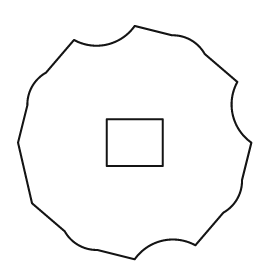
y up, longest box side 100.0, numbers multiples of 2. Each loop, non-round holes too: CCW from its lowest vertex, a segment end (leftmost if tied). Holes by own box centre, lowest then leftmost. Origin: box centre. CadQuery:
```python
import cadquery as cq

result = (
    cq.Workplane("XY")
    .moveTo(0.0, -50.0)
    .threePointArc((12.0, -42.0), (26.0, -44.0))
    .lineTo(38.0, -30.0)
    .threePointArc((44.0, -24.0), (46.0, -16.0))
    .lineTo(50.0, 0.0)
    .threePointArc((42.0, 12.0), (44.0, 26.0))
    .lineTo(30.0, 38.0)
    .threePointArc((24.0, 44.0), (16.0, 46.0))
    .lineTo(0.0, 50.0)
    .threePointArc((-12.0, 42.0), (-26.0, 44.0))
    .lineTo(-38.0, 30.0)
    .threePointArc((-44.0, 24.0), (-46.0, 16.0))
    .lineTo(-50.0, 0.0)
    .lineTo(-44.0, -26.0)
    .lineTo(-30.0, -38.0)
    .threePointArc((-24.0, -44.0), (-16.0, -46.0))
    .close()
    .moveTo(-12.0, -10.0)
    .lineTo(12.0, -10.0)
    .lineTo(12.0, 10.0)
    .lineTo(-12.0, 10.0)
    .close()
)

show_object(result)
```